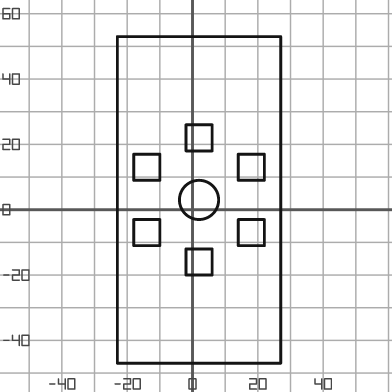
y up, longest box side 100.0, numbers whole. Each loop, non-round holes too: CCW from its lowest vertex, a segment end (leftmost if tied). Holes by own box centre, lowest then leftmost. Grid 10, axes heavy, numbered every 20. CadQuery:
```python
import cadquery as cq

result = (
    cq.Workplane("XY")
    .moveTo(-23.0, -47.0)
    .lineTo(27.0, -47.0)
    .lineTo(27.0, 53.0)
    .lineTo(-23.0, 53.0)
    .close()
    .moveTo(-2.0, -20.0)
    .lineTo(6.0, -20.0)
    .lineTo(6.0, -12.0)
    .lineTo(-2.0, -12.0)
    .close()
    .moveTo(-18.0, -11.0)
    .lineTo(-10.0, -11.0)
    .lineTo(-10.0, -3.0)
    .lineTo(-18.0, -3.0)
    .close()
    .moveTo(14.0, -11.0)
    .lineTo(22.0, -11.0)
    .lineTo(22.0, -3.0)
    .lineTo(14.0, -3.0)
    .close()
    .moveTo(2.0, 3.0)
    .circle(6.0)
    .moveTo(-18.0, 9.0)
    .lineTo(-10.0, 9.0)
    .lineTo(-10.0, 17.0)
    .lineTo(-18.0, 17.0)
    .close()
    .moveTo(14.0, 9.0)
    .lineTo(22.0, 9.0)
    .lineTo(22.0, 17.0)
    .lineTo(14.0, 17.0)
    .close()
    .moveTo(-2.0, 18.0)
    .lineTo(6.0, 18.0)
    .lineTo(6.0, 26.0)
    .lineTo(-2.0, 26.0)
    .close()
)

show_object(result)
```